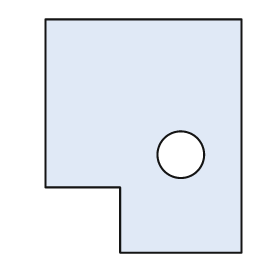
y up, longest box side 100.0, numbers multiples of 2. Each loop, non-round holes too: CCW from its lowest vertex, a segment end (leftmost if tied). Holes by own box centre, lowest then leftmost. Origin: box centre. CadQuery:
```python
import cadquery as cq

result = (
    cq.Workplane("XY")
    .moveTo(-10.0, -50.0)
    .lineTo(42.0, -50.0)
    .lineTo(42.0, 50.0)
    .lineTo(-42.0, 50.0)
    .lineTo(-42.0, -22.0)
    .lineTo(-10.0, -22.0)
    .close()
    .moveTo(16.0, -8.0)
    .circle(10.0)
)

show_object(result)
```